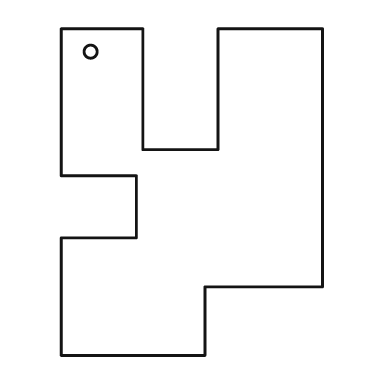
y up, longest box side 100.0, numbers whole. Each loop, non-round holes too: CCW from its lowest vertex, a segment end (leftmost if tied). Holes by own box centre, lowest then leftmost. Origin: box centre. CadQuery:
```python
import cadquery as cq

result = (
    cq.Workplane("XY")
    .moveTo(-40.0, -50.0)
    .lineTo(4.0, -50.0)
    .lineTo(4.0, -29.0)
    .lineTo(40.0, -29.0)
    .lineTo(40.0, 50.0)
    .lineTo(8.0, 50.0)
    .lineTo(8.0, 13.0)
    .lineTo(-15.0, 13.0)
    .lineTo(-15.0, 50.0)
    .lineTo(-40.0, 50.0)
    .lineTo(-40.0, 5.0)
    .lineTo(-17.0, 5.0)
    .lineTo(-17.0, -14.0)
    .lineTo(-40.0, -14.0)
    .close()
    .moveTo(-31.0, 43.0)
    .circle(2.0)
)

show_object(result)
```